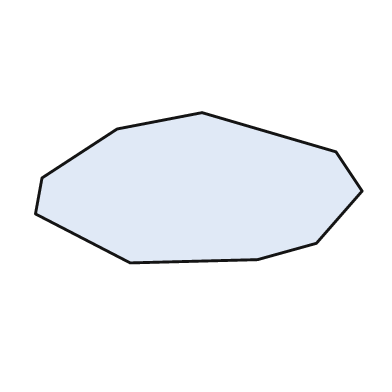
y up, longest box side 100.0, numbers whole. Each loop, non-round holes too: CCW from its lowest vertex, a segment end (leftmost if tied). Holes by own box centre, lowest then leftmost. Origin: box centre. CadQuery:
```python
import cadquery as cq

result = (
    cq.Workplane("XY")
    .moveTo(-21.0, -23.0)
    .lineTo(18.0, -22.0)
    .lineTo(36.0, -17.0)
    .lineTo(50.0, -1.0)
    .lineTo(42.0, 11.0)
    .lineTo(1.0, 23.0)
    .lineTo(-25.0, 18.0)
    .lineTo(-48.0, 3.0)
    .lineTo(-50.0, -8.0)
    .close()
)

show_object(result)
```